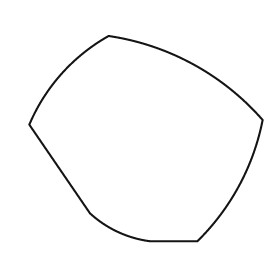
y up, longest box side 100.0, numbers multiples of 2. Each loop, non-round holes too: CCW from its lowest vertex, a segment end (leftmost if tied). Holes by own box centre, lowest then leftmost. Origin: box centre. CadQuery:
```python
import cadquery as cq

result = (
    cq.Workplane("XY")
    .moveTo(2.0, -44.0)
    .lineTo(22.0, -44.0)
    .threePointArc((40.0, -20.0), (50.0, 8.0))
    .threePointArc((20.0, 32.0), (-16.0, 44.0))
    .threePointArc((-36.0, 28.0), (-50.0, 6.0))
    .lineTo(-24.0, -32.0)
    .threePointArc((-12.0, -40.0), (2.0, -44.0))
    .close()
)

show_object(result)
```